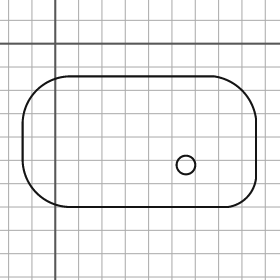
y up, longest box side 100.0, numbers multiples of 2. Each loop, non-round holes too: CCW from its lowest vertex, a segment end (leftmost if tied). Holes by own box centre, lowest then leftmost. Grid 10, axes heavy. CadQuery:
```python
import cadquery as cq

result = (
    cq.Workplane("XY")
    .moveTo(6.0, -70.0)
    .lineTo(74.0, -70.0)
    .threePointArc((82.0, -66.0), (86.0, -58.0))
    .lineTo(86.0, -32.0)
    .threePointArc((80.0, -20.0), (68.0, -14.0))
    .lineTo(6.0, -14.0)
    .threePointArc((-8.0, -20.0), (-14.0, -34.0))
    .lineTo(-14.0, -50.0)
    .threePointArc((-8.0, -64.0), (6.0, -70.0))
    .close()
    .moveTo(56.0, -52.0)
    .circle(4.0)
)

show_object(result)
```